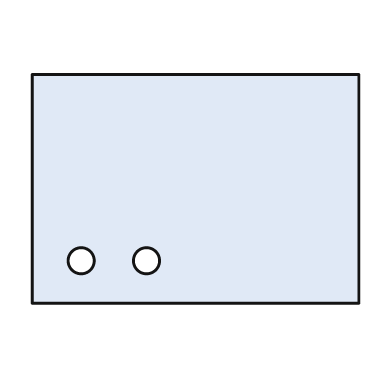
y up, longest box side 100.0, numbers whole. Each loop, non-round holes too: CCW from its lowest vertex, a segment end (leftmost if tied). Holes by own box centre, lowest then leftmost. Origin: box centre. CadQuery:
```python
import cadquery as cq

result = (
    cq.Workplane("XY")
    .moveTo(-50.0, -35.0)
    .lineTo(50.0, -35.0)
    .lineTo(50.0, 35.0)
    .lineTo(-50.0, 35.0)
    .close()
    .moveTo(-35.0, -22.0)
    .circle(4.0)
    .moveTo(-15.0, -22.0)
    .circle(4.0)
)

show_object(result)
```